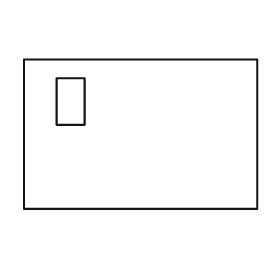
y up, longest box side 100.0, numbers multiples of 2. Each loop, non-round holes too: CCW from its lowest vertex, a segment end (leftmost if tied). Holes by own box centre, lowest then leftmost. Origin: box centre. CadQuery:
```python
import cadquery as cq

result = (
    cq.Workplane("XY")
    .moveTo(-50.0, -32.0)
    .lineTo(50.0, -32.0)
    .lineTo(50.0, 32.0)
    .lineTo(-50.0, 32.0)
    .close()
    .moveTo(-36.0, 4.0)
    .lineTo(-24.0, 4.0)
    .lineTo(-24.0, 24.0)
    .lineTo(-36.0, 24.0)
    .close()
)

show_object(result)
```